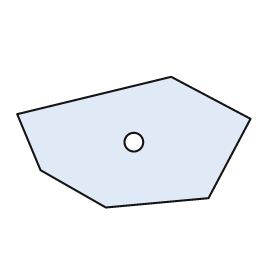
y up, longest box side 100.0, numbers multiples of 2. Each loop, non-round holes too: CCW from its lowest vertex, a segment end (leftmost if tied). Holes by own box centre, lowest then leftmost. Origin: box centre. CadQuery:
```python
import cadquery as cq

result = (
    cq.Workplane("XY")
    .moveTo(-12.0, -28.0)
    .lineTo(32.0, -24.0)
    .lineTo(50.0, 10.0)
    .lineTo(16.0, 28.0)
    .lineTo(-50.0, 12.0)
    .lineTo(-40.0, -12.0)
    .close()
    .moveTo(0.0, 0.0)
    .circle(4.0)
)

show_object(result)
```